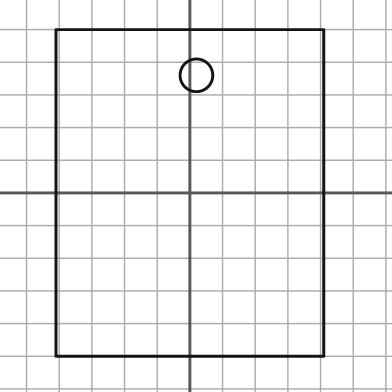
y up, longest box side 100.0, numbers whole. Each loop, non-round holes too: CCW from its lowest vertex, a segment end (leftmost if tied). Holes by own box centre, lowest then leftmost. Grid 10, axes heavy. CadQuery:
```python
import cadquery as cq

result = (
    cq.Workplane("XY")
    .moveTo(-41.0, -50.0)
    .lineTo(41.0, -50.0)
    .lineTo(41.0, 50.0)
    .lineTo(-41.0, 50.0)
    .close()
    .moveTo(2.0, 36.0)
    .circle(5.0)
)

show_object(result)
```